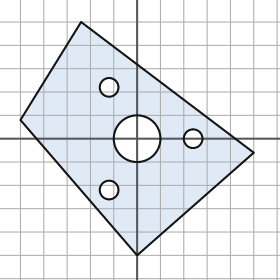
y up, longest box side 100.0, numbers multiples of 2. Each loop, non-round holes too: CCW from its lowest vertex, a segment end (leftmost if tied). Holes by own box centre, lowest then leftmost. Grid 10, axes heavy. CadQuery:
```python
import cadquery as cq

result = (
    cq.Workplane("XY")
    .moveTo(0.0, -50.0)
    .lineTo(50.0, -6.0)
    .lineTo(-24.0, 50.0)
    .lineTo(-50.0, 8.0)
    .close()
    .moveTo(-12.0, -22.0)
    .circle(4.0)
    .moveTo(0.0, 0.0)
    .circle(10.0)
    .moveTo(24.0, 0.0)
    .circle(4.0)
    .moveTo(-12.0, 22.0)
    .circle(4.0)
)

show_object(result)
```